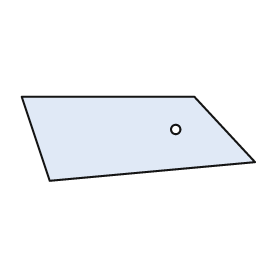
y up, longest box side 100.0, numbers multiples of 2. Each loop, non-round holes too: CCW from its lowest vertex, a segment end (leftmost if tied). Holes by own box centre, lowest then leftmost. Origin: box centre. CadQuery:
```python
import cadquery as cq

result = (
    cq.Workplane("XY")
    .moveTo(-38.0, -18.0)
    .lineTo(50.0, -10.0)
    .lineTo(24.0, 18.0)
    .lineTo(-50.0, 18.0)
    .close()
    .moveTo(16.0, 4.0)
    .circle(2.0)
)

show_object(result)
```